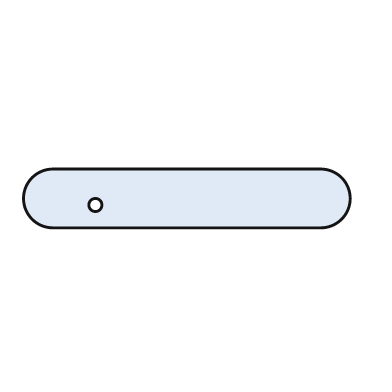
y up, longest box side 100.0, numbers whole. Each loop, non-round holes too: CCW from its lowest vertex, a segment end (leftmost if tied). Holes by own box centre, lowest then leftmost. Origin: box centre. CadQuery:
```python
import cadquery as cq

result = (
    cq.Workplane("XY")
    .moveTo(-41.0, -9.0)
    .lineTo(41.0, -9.0)
    .threePointArc((50.0, 0.0), (41.0, 9.0))
    .lineTo(-41.0, 9.0)
    .threePointArc((-50.0, 0.0), (-41.0, -9.0))
    .close()
    .moveTo(-28.0, -2.0)
    .circle(2.0)
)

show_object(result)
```